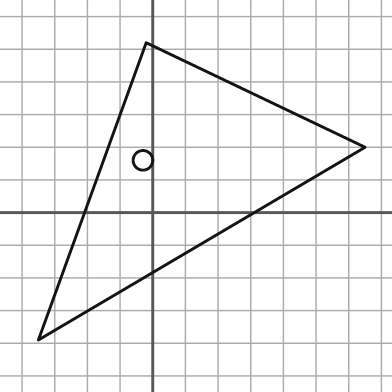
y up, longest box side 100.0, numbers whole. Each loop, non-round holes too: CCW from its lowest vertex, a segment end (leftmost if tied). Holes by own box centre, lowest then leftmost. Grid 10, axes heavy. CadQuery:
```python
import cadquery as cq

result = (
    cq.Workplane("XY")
    .moveTo(-35.0, -39.0)
    .lineTo(65.0, 20.0)
    .lineTo(-2.0, 52.0)
    .close()
    .moveTo(-3.0, 16.0)
    .circle(3.0)
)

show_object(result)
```